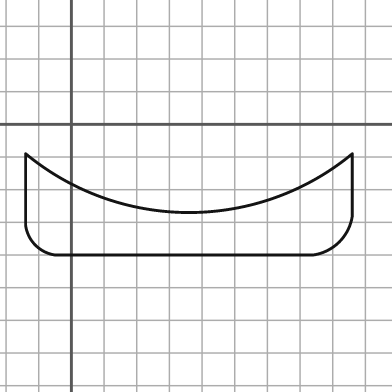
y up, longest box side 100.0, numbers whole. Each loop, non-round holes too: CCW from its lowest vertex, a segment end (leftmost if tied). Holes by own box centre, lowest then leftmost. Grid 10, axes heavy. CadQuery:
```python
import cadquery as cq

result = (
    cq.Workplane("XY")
    .moveTo(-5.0, -40.0)
    .lineTo(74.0, -40.0)
    .threePointArc((82.0, -36.0), (86.0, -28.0))
    .lineTo(86.0, -9.0)
    .threePointArc((36.0, -27.0), (-14.0, -9.0))
    .lineTo(-14.0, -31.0)
    .threePointArc((-11.0, -37.0), (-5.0, -40.0))
    .close()
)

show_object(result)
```